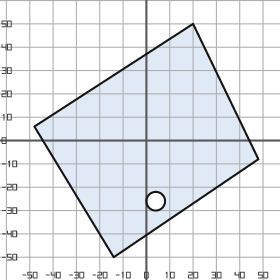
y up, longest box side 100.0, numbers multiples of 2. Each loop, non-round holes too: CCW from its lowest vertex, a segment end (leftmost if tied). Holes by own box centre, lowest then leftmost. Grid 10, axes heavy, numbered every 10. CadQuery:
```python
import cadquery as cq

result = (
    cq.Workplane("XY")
    .moveTo(-14.0, -50.0)
    .lineTo(48.0, -8.0)
    .lineTo(20.0, 50.0)
    .lineTo(-48.0, 6.0)
    .close()
    .moveTo(4.0, -26.0)
    .circle(4.0)
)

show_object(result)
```